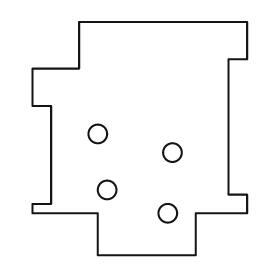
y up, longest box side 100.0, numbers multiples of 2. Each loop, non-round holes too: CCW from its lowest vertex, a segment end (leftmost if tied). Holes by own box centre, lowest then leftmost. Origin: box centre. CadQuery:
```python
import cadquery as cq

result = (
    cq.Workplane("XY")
    .moveTo(-18.0, -50.0)
    .lineTo(24.0, -50.0)
    .lineTo(24.0, -32.0)
    .lineTo(46.0, -32.0)
    .lineTo(46.0, -24.0)
    .lineTo(38.0, -24.0)
    .lineTo(38.0, 34.0)
    .lineTo(46.0, 34.0)
    .lineTo(46.0, 50.0)
    .lineTo(-26.0, 50.0)
    .lineTo(-26.0, 30.0)
    .lineTo(-46.0, 30.0)
    .lineTo(-46.0, 14.0)
    .lineTo(-38.0, 14.0)
    .lineTo(-38.0, -28.0)
    .lineTo(-46.0, -28.0)
    .lineTo(-46.0, -32.0)
    .lineTo(-18.0, -32.0)
    .close()
    .moveTo(12.0, -32.0)
    .circle(4.0)
    .moveTo(-14.0, -22.0)
    .circle(4.0)
    .moveTo(14.0, -6.0)
    .circle(4.0)
    .moveTo(-18.0, 2.0)
    .circle(4.0)
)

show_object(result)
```